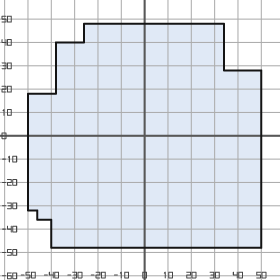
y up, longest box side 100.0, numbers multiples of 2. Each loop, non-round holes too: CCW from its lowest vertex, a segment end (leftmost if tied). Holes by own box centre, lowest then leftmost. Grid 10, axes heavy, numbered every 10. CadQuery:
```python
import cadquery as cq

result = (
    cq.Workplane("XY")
    .moveTo(-40.0, -48.0)
    .lineTo(50.0, -48.0)
    .lineTo(50.0, 28.0)
    .lineTo(34.0, 28.0)
    .lineTo(34.0, 48.0)
    .lineTo(-26.0, 48.0)
    .lineTo(-26.0, 40.0)
    .lineTo(-38.0, 40.0)
    .lineTo(-38.0, 18.0)
    .lineTo(-50.0, 18.0)
    .lineTo(-50.0, -32.0)
    .lineTo(-46.0, -32.0)
    .lineTo(-46.0, -36.0)
    .lineTo(-40.0, -36.0)
    .close()
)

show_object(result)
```